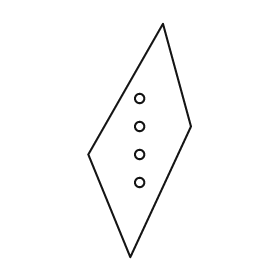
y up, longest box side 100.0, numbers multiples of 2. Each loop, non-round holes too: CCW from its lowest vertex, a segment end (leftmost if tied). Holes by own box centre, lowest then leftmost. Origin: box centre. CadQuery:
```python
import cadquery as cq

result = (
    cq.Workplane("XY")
    .moveTo(-4.0, -50.0)
    .lineTo(22.0, 6.0)
    .lineTo(10.0, 50.0)
    .lineTo(-22.0, -6.0)
    .close()
    .moveTo(0.0, -18.0)
    .circle(2.0)
    .moveTo(0.0, -6.0)
    .circle(2.0)
    .moveTo(0.0, 6.0)
    .circle(2.0)
    .moveTo(0.0, 18.0)
    .circle(2.0)
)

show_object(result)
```